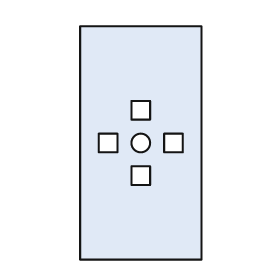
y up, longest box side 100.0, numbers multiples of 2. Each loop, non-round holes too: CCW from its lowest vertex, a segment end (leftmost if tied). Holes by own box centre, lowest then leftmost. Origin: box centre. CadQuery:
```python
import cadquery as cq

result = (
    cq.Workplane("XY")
    .moveTo(-26.0, -50.0)
    .lineTo(26.0, -50.0)
    .lineTo(26.0, 50.0)
    .lineTo(-26.0, 50.0)
    .close()
    .moveTo(-4.0, -18.0)
    .lineTo(4.0, -18.0)
    .lineTo(4.0, -10.0)
    .lineTo(-4.0, -10.0)
    .close()
    .moveTo(-18.0, -4.0)
    .lineTo(-10.0, -4.0)
    .lineTo(-10.0, 4.0)
    .lineTo(-18.0, 4.0)
    .close()
    .moveTo(0.0, 0.0)
    .circle(4.0)
    .moveTo(10.0, -4.0)
    .lineTo(18.0, -4.0)
    .lineTo(18.0, 4.0)
    .lineTo(10.0, 4.0)
    .close()
    .moveTo(-4.0, 10.0)
    .lineTo(4.0, 10.0)
    .lineTo(4.0, 18.0)
    .lineTo(-4.0, 18.0)
    .close()
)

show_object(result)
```